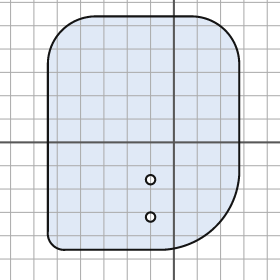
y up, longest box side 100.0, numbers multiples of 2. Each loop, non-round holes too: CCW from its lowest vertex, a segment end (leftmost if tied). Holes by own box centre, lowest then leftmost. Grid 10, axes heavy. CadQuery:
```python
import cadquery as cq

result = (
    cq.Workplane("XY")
    .moveTo(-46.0, -46.0)
    .lineTo(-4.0, -46.0)
    .threePointArc((18.0, -36.0), (28.0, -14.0))
    .lineTo(28.0, 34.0)
    .threePointArc((22.0, 48.0), (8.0, 54.0))
    .lineTo(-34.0, 54.0)
    .threePointArc((-48.0, 48.0), (-54.0, 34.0))
    .lineTo(-54.0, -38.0)
    .threePointArc((-52.0, -44.0), (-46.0, -46.0))
    .close()
    .moveTo(-10.0, -32.0)
    .circle(2.0)
    .moveTo(-10.0, -16.0)
    .circle(2.0)
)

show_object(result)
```